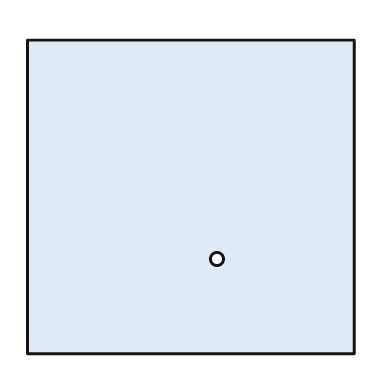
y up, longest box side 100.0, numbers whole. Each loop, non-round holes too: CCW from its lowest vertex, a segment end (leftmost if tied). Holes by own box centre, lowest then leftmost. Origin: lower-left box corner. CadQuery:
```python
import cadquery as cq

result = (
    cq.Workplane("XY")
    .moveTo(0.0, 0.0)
    .lineTo(100.0, 0.0)
    .lineTo(100.0, 96.0)
    .lineTo(0.0, 96.0)
    .close()
    .moveTo(58.0, 29.0)
    .circle(2.0)
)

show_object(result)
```